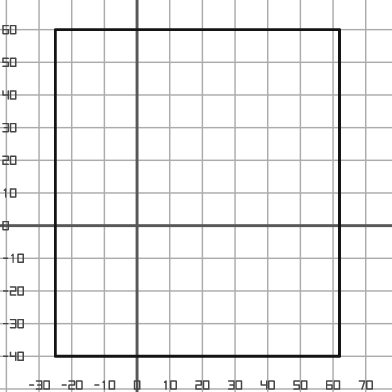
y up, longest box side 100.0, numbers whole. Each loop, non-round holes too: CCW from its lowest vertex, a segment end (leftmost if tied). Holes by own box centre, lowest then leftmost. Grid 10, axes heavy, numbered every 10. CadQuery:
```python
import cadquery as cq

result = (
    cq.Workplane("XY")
    .moveTo(-25.0, -40.0)
    .lineTo(62.0, -40.0)
    .lineTo(62.0, 60.0)
    .lineTo(-25.0, 60.0)
    .close()
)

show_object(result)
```